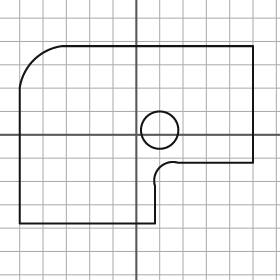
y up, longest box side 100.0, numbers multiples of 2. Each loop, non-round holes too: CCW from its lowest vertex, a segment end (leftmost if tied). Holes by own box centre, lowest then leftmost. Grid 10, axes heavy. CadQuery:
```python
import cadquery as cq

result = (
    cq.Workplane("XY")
    .moveTo(-50.0, -38.0)
    .lineTo(8.0, -38.0)
    .lineTo(8.0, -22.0)
    .threePointArc((10.0, -14.0), (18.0, -12.0))
    .lineTo(50.0, -12.0)
    .lineTo(50.0, 38.0)
    .lineTo(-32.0, 38.0)
    .threePointArc((-44.0, 32.0), (-50.0, 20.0))
    .close()
    .moveTo(10.0, 2.0)
    .circle(8.0)
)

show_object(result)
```